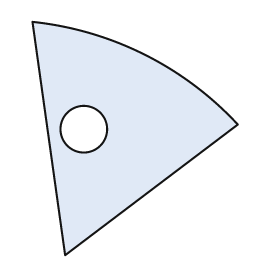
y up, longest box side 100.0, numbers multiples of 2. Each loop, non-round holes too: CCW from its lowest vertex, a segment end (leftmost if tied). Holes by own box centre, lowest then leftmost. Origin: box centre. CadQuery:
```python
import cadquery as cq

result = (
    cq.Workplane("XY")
    .moveTo(-30.0, -50.0)
    .lineTo(44.0, 6.0)
    .threePointArc((4.0, 36.0), (-44.0, 50.0))
    .close()
    .moveTo(-22.0, 4.0)
    .circle(10.0)
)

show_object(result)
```